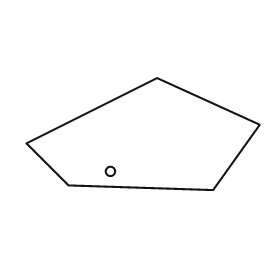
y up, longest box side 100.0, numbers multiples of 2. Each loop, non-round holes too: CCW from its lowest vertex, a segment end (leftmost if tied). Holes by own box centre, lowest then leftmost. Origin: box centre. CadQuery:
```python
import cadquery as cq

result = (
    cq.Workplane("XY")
    .moveTo(30.0, -24.0)
    .lineTo(50.0, 4.0)
    .lineTo(6.0, 24.0)
    .lineTo(-50.0, -4.0)
    .lineTo(-32.0, -22.0)
    .close()
    .moveTo(-14.0, -16.0)
    .circle(2.0)
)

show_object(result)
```